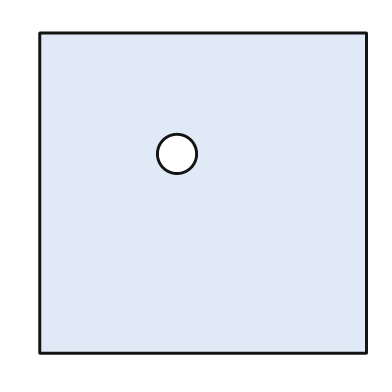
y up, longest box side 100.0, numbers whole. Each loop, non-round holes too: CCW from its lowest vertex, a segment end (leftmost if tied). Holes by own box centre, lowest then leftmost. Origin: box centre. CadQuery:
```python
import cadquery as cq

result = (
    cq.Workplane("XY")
    .moveTo(-50.0, -49.0)
    .lineTo(50.0, -49.0)
    .lineTo(50.0, 49.0)
    .lineTo(-50.0, 49.0)
    .close()
    .moveTo(-8.0, 12.0)
    .circle(6.0)
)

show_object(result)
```